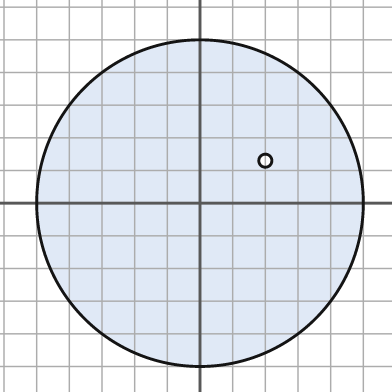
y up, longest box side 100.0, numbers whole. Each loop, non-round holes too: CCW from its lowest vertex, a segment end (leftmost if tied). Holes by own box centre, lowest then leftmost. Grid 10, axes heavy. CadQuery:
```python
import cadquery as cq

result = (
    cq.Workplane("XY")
    .moveTo(0.0, 0.0)
    .circle(50.0)
    .moveTo(20.0, 13.0)
    .circle(2.0)
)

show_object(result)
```